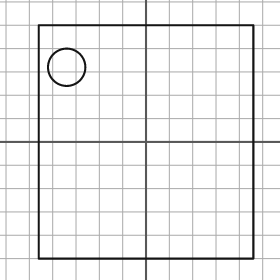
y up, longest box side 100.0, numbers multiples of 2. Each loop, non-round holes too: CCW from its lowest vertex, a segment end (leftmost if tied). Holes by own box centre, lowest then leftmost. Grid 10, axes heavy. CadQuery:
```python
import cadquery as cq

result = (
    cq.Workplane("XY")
    .moveTo(-46.0, -50.0)
    .lineTo(46.0, -50.0)
    .lineTo(46.0, 50.0)
    .lineTo(-46.0, 50.0)
    .close()
    .moveTo(-34.0, 32.0)
    .circle(8.0)
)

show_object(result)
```